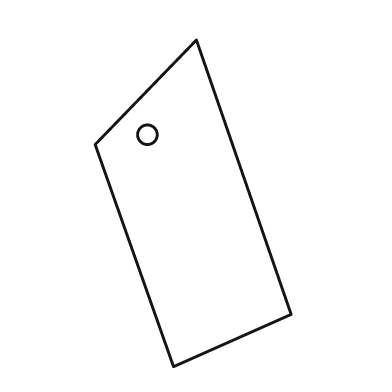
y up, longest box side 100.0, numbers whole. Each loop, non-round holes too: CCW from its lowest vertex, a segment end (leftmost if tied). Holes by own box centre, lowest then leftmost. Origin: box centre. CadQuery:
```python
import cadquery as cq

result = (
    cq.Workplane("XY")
    .moveTo(-6.0, -50.0)
    .lineTo(30.0, -34.0)
    .lineTo(1.0, 50.0)
    .lineTo(-30.0, 18.0)
    .close()
    .moveTo(-14.0, 21.0)
    .circle(3.0)
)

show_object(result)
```